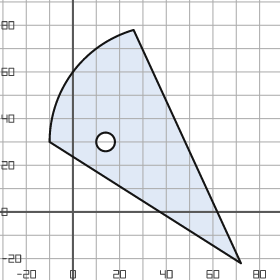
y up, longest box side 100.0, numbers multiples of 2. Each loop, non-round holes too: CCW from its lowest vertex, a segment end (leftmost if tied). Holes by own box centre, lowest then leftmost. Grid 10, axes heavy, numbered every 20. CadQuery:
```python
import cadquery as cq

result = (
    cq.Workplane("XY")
    .moveTo(72.0, -22.0)
    .lineTo(26.0, 78.0)
    .threePointArc((0.0, 60.0), (-10.0, 30.0))
    .close()
    .moveTo(14.0, 30.0)
    .circle(4.0)
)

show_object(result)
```